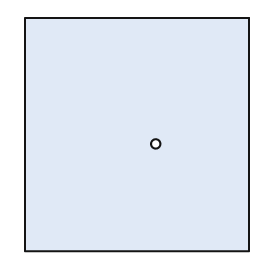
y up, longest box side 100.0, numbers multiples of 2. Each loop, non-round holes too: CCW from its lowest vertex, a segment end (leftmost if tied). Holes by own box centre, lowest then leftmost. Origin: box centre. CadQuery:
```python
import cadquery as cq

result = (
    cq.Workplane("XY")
    .moveTo(-48.0, -50.0)
    .lineTo(48.0, -50.0)
    .lineTo(48.0, 50.0)
    .lineTo(-48.0, 50.0)
    .close()
    .moveTo(8.0, -4.0)
    .circle(2.0)
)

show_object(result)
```